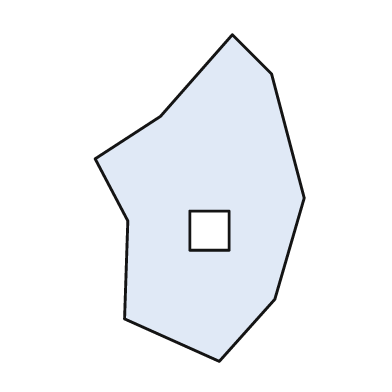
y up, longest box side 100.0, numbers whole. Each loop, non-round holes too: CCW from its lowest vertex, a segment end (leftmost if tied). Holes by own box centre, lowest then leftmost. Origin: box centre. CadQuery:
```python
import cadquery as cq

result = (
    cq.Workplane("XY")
    .moveTo(6.0, -50.0)
    .lineTo(23.0, -31.0)
    .lineTo(32.0, 0.0)
    .lineTo(22.0, 38.0)
    .lineTo(10.0, 50.0)
    .lineTo(-12.0, 25.0)
    .lineTo(-32.0, 12.0)
    .lineTo(-22.0, -7.0)
    .lineTo(-23.0, -37.0)
    .close()
    .moveTo(-3.0, -16.0)
    .lineTo(9.0, -16.0)
    .lineTo(9.0, -4.0)
    .lineTo(-3.0, -4.0)
    .close()
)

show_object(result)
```